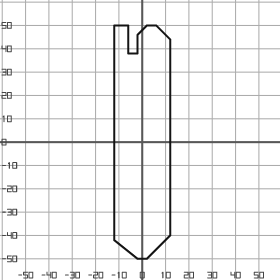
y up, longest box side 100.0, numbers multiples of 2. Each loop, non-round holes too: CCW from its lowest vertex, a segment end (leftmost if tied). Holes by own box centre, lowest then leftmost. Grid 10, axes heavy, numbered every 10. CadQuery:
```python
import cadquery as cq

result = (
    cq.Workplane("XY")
    .moveTo(-2.0, -50.0)
    .lineTo(2.0, -50.0)
    .lineTo(12.0, -40.0)
    .lineTo(12.0, 44.0)
    .lineTo(6.0, 50.0)
    .lineTo(2.0, 50.0)
    .lineTo(-2.0, 46.0)
    .lineTo(-2.0, 38.0)
    .lineTo(-6.0, 38.0)
    .lineTo(-6.0, 50.0)
    .lineTo(-12.0, 50.0)
    .lineTo(-12.0, -42.0)
    .close()
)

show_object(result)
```